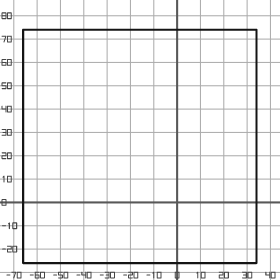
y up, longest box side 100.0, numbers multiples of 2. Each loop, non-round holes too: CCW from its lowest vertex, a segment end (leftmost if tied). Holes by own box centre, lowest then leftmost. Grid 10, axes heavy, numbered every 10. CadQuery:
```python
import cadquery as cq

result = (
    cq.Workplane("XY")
    .moveTo(-66.0, -26.0)
    .lineTo(34.0, -26.0)
    .lineTo(34.0, 74.0)
    .lineTo(-66.0, 74.0)
    .close()
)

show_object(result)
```